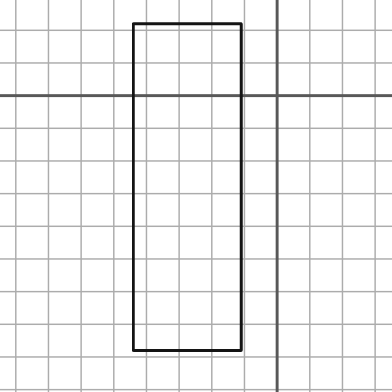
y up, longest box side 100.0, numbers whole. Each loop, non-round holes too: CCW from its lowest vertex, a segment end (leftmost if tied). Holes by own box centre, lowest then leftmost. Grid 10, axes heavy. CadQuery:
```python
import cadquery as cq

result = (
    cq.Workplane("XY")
    .moveTo(-44.0, -78.0)
    .lineTo(-11.0, -78.0)
    .lineTo(-11.0, 22.0)
    .lineTo(-44.0, 22.0)
    .close()
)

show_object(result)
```